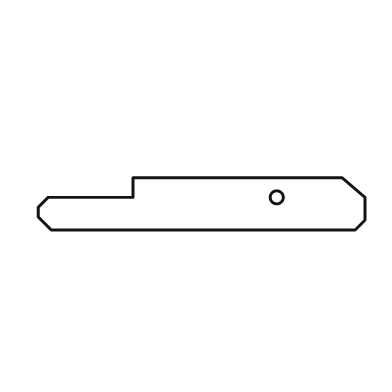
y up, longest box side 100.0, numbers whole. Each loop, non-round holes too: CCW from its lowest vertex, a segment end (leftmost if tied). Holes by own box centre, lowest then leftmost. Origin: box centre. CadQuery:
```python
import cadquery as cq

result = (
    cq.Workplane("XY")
    .moveTo(-46.0, -8.0)
    .lineTo(47.0, -8.0)
    .lineTo(50.0, -5.0)
    .lineTo(50.0, 2.0)
    .lineTo(43.0, 8.0)
    .lineTo(-21.0, 8.0)
    .lineTo(-21.0, 2.0)
    .lineTo(-47.0, 2.0)
    .lineTo(-50.0, -1.0)
    .lineTo(-50.0, -4.0)
    .close()
    .moveTo(23.0, 2.0)
    .circle(2.0)
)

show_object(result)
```